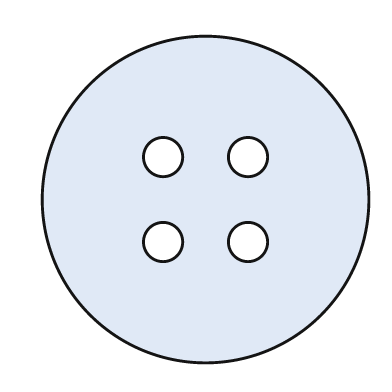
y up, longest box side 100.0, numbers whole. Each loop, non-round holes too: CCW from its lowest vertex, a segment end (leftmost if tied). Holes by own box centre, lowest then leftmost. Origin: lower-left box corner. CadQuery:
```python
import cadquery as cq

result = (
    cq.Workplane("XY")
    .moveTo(50.0, 50.0)
    .circle(50.0)
    .moveTo(37.0, 37.0)
    .circle(6.0)
    .moveTo(63.0, 37.0)
    .circle(6.0)
    .moveTo(37.0, 63.0)
    .circle(6.0)
    .moveTo(63.0, 63.0)
    .circle(6.0)
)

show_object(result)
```